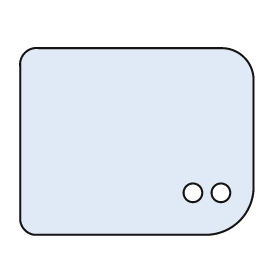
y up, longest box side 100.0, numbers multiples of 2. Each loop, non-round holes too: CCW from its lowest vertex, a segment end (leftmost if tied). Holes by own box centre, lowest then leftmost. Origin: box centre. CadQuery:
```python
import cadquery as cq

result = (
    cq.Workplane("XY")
    .moveTo(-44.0, -40.0)
    .lineTo(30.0, -40.0)
    .threePointArc((44.0, -34.0), (50.0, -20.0))
    .lineTo(50.0, 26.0)
    .threePointArc((46.0, 36.0), (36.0, 40.0))
    .lineTo(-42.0, 40.0)
    .threePointArc((-48.0, 38.0), (-50.0, 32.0))
    .lineTo(-50.0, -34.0)
    .threePointArc((-48.0, -38.0), (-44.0, -40.0))
    .close()
    .moveTo(24.0, -22.0)
    .circle(4.0)
    .moveTo(36.0, -22.0)
    .circle(4.0)
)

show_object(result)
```